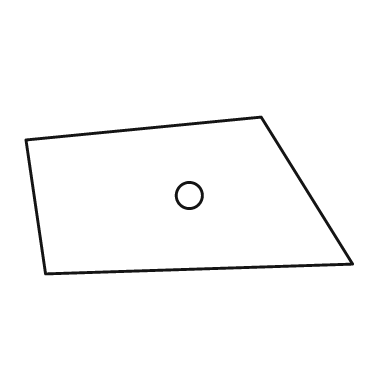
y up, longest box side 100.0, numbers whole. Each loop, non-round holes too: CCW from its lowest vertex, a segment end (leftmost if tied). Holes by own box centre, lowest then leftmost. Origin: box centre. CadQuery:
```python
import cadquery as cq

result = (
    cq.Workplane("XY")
    .moveTo(-44.0, -24.0)
    .lineTo(50.0, -21.0)
    .lineTo(22.0, 24.0)
    .lineTo(-50.0, 17.0)
    .close()
    .moveTo(0.0, 0.0)
    .circle(4.0)
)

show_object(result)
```